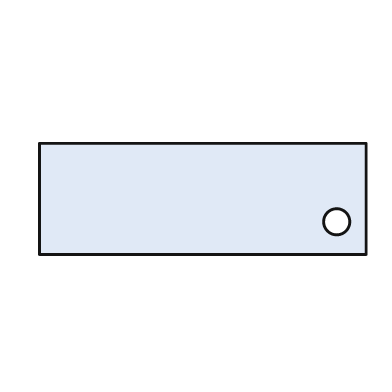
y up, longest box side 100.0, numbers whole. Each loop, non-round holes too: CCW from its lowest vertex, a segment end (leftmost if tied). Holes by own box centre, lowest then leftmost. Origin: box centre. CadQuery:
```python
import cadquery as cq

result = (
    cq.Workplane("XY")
    .moveTo(-50.0, -17.0)
    .lineTo(50.0, -17.0)
    .lineTo(50.0, 17.0)
    .lineTo(-50.0, 17.0)
    .close()
    .moveTo(41.0, -7.0)
    .circle(4.0)
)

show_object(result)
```